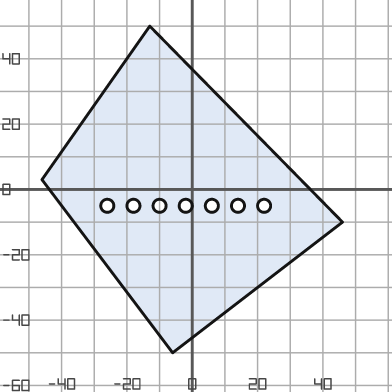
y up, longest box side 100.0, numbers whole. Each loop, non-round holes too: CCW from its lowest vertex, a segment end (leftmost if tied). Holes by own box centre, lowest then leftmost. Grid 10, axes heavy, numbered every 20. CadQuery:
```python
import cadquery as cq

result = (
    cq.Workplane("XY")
    .moveTo(-6.0, -50.0)
    .lineTo(46.0, -10.0)
    .lineTo(-13.0, 50.0)
    .lineTo(-46.0, 3.0)
    .close()
    .moveTo(-26.0, -5.0)
    .circle(2.0)
    .moveTo(-18.0, -5.0)
    .circle(2.0)
    .moveTo(-10.0, -5.0)
    .circle(2.0)
    .moveTo(-2.0, -5.0)
    .circle(2.0)
    .moveTo(6.0, -5.0)
    .circle(2.0)
    .moveTo(14.0, -5.0)
    .circle(2.0)
    .moveTo(22.0, -5.0)
    .circle(2.0)
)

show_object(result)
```